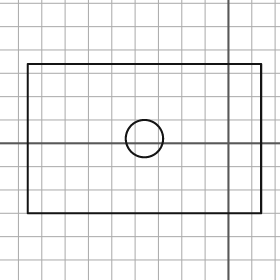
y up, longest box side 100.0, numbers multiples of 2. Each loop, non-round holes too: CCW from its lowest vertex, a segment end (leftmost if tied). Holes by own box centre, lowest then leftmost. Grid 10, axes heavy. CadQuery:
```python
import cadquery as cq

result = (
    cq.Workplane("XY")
    .moveTo(-86.0, -30.0)
    .lineTo(14.0, -30.0)
    .lineTo(14.0, 34.0)
    .lineTo(-86.0, 34.0)
    .close()
    .moveTo(-36.0, 2.0)
    .circle(8.0)
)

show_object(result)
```